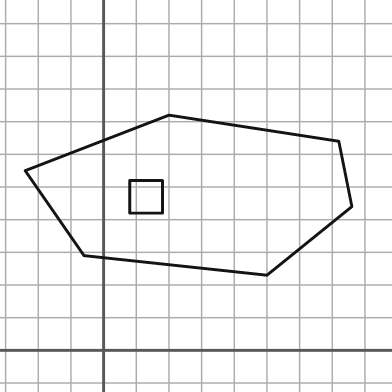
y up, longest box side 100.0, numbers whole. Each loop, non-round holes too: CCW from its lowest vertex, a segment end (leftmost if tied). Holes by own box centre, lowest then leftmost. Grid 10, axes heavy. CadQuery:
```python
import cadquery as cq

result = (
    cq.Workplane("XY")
    .moveTo(50.0, 23.0)
    .lineTo(76.0, 44.0)
    .lineTo(72.0, 64.0)
    .lineTo(20.0, 72.0)
    .lineTo(-24.0, 55.0)
    .lineTo(-6.0, 29.0)
    .close()
    .moveTo(8.0, 42.0)
    .lineTo(18.0, 42.0)
    .lineTo(18.0, 52.0)
    .lineTo(8.0, 52.0)
    .close()
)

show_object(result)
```